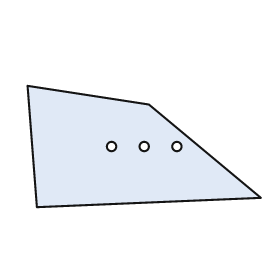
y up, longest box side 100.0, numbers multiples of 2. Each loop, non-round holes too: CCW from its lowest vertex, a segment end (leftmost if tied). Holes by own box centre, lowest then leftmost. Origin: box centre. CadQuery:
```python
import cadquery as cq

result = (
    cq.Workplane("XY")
    .moveTo(-46.0, -26.0)
    .lineTo(50.0, -22.0)
    .lineTo(2.0, 18.0)
    .lineTo(-50.0, 26.0)
    .close()
    .moveTo(-14.0, 0.0)
    .circle(2.0)
    .moveTo(0.0, 0.0)
    .circle(2.0)
    .moveTo(14.0, 0.0)
    .circle(2.0)
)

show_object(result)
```